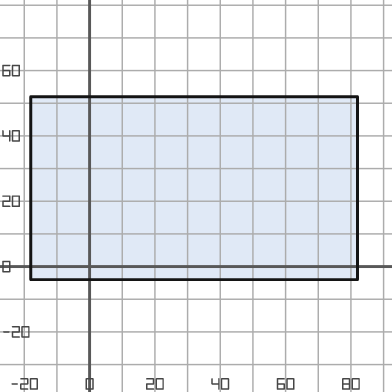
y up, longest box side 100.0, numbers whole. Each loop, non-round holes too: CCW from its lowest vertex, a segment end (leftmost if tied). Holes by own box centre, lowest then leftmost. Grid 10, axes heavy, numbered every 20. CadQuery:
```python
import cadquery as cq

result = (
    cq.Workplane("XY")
    .moveTo(-18.0, -4.0)
    .lineTo(82.0, -4.0)
    .lineTo(82.0, 52.0)
    .lineTo(-18.0, 52.0)
    .close()
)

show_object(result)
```